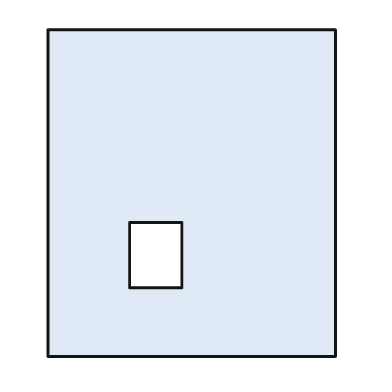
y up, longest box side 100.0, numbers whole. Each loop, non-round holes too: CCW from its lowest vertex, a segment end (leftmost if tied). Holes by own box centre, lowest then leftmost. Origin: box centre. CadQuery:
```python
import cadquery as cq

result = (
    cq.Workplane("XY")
    .moveTo(-44.0, -50.0)
    .lineTo(44.0, -50.0)
    .lineTo(44.0, 50.0)
    .lineTo(-44.0, 50.0)
    .close()
    .moveTo(-19.0, -29.0)
    .lineTo(-3.0, -29.0)
    .lineTo(-3.0, -9.0)
    .lineTo(-19.0, -9.0)
    .close()
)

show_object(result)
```